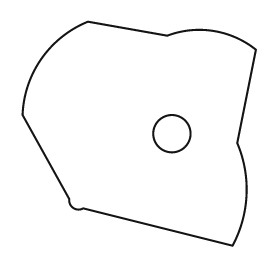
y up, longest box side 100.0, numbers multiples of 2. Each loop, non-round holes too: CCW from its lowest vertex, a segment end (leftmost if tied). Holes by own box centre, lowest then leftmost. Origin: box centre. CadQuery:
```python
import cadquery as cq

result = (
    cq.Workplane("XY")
    .moveTo(40.0, -48.0)
    .threePointArc((46.0, -26.0), (42.0, -4.0))
    .lineTo(50.0, 36.0)
    .threePointArc((32.0, 44.0), (12.0, 42.0))
    .lineTo(-22.0, 48.0)
    .threePointArc((-42.0, 32.0), (-50.0, 8.0))
    .lineTo(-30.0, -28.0)
    .threePointArc((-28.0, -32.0), (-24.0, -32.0))
    .close()
    .moveTo(14.0, 0.0)
    .circle(8.0)
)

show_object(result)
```